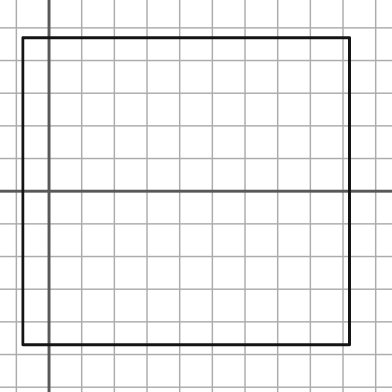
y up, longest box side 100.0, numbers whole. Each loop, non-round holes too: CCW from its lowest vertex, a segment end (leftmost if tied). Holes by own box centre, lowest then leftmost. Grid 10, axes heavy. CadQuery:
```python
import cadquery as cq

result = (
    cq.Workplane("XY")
    .moveTo(-8.0, -47.0)
    .lineTo(92.0, -47.0)
    .lineTo(92.0, 47.0)
    .lineTo(-8.0, 47.0)
    .close()
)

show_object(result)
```